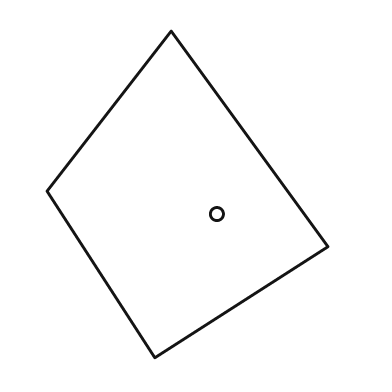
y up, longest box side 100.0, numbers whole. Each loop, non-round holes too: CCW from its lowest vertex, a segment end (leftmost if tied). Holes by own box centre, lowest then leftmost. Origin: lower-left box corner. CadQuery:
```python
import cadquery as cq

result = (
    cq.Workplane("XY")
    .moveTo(33.0, 0.0)
    .lineTo(86.0, 34.0)
    .lineTo(38.0, 100.0)
    .lineTo(0.0, 51.0)
    .close()
    .moveTo(52.0, 44.0)
    .circle(2.0)
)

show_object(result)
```